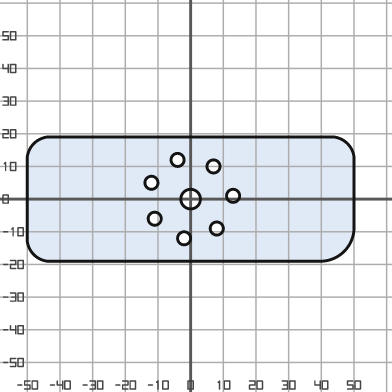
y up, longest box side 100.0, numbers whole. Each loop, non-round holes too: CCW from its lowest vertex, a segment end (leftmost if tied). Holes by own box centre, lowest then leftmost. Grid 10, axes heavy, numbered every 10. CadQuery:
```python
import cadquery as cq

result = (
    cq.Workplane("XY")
    .moveTo(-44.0, -19.0)
    .lineTo(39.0, -19.0)
    .threePointArc((47.0, -16.0), (50.0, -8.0))
    .lineTo(50.0, 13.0)
    .threePointArc((48.0, 17.0), (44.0, 19.0))
    .lineTo(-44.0, 19.0)
    .threePointArc((-48.0, 17.0), (-50.0, 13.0))
    .lineTo(-50.0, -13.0)
    .threePointArc((-48.0, -17.0), (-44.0, -19.0))
    .close()
    .moveTo(-2.0, -12.0)
    .circle(2.0)
    .moveTo(8.0, -9.0)
    .circle(2.0)
    .moveTo(-11.0, -6.0)
    .circle(2.0)
    .moveTo(0.0, 0.0)
    .circle(3.0)
    .moveTo(13.0, 1.0)
    .circle(2.0)
    .moveTo(-12.0, 5.0)
    .circle(2.0)
    .moveTo(7.0, 10.0)
    .circle(2.0)
    .moveTo(-4.0, 12.0)
    .circle(2.0)
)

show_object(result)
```